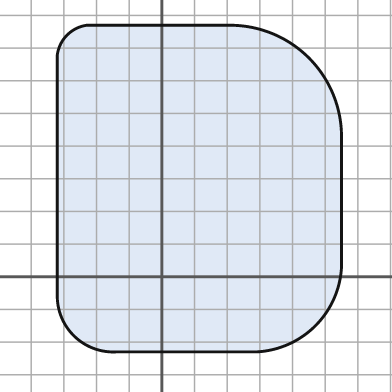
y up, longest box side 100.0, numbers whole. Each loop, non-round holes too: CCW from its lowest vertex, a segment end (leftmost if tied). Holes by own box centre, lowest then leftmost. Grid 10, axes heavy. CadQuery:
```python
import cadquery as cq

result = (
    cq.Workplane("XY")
    .moveTo(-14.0, -23.0)
    .lineTo(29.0, -23.0)
    .threePointArc((47.0, -15.0), (55.0, 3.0))
    .lineTo(55.0, 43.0)
    .threePointArc((45.0, 67.0), (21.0, 77.0))
    .lineTo(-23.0, 77.0)
    .threePointArc((-29.0, 74.0), (-32.0, 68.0))
    .lineTo(-32.0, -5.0)
    .threePointArc((-27.0, -18.0), (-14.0, -23.0))
    .close()
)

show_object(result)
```